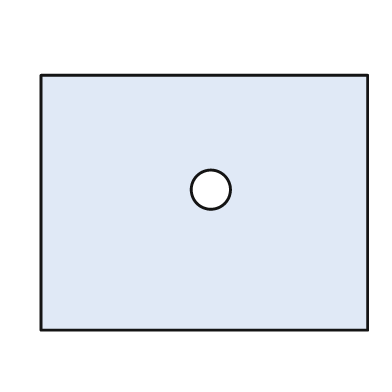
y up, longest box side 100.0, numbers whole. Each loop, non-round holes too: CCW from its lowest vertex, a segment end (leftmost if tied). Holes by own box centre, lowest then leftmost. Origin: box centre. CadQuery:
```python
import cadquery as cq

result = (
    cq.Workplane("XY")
    .moveTo(-50.0, -39.0)
    .lineTo(50.0, -39.0)
    .lineTo(50.0, 39.0)
    .lineTo(-50.0, 39.0)
    .close()
    .moveTo(2.0, 4.0)
    .circle(6.0)
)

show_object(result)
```